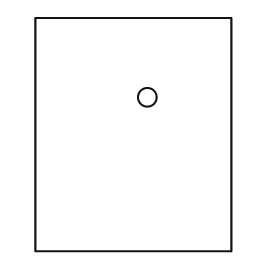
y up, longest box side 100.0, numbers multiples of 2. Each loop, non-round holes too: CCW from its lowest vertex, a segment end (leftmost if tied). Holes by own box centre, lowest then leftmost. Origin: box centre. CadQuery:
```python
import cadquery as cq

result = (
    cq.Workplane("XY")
    .moveTo(-42.0, -50.0)
    .lineTo(42.0, -50.0)
    .lineTo(42.0, 50.0)
    .lineTo(-42.0, 50.0)
    .close()
    .moveTo(6.0, 16.0)
    .circle(4.0)
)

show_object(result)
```